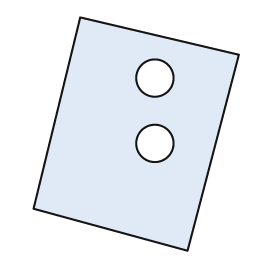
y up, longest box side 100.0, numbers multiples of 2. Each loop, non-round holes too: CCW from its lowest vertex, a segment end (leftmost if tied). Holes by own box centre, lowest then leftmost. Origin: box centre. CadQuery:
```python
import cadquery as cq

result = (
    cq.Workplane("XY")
    .moveTo(22.0, -50.0)
    .lineTo(44.0, 34.0)
    .lineTo(-24.0, 50.0)
    .lineTo(-44.0, -32.0)
    .close()
    .moveTo(8.0, -4.0)
    .circle(8.0)
    .moveTo(8.0, 24.0)
    .circle(8.0)
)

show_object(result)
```